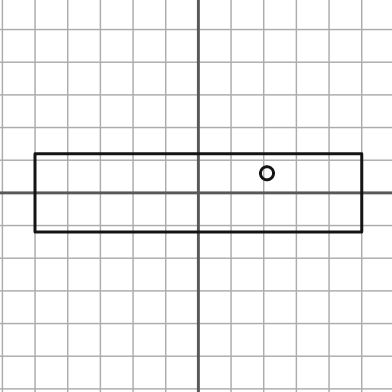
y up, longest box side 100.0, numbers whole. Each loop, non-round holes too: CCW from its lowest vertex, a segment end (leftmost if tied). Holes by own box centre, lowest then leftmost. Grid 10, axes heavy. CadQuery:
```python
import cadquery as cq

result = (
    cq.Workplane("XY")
    .moveTo(-50.0, -12.0)
    .lineTo(50.0, -12.0)
    .lineTo(50.0, 12.0)
    .lineTo(-50.0, 12.0)
    .close()
    .moveTo(21.0, 6.0)
    .circle(2.0)
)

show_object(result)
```